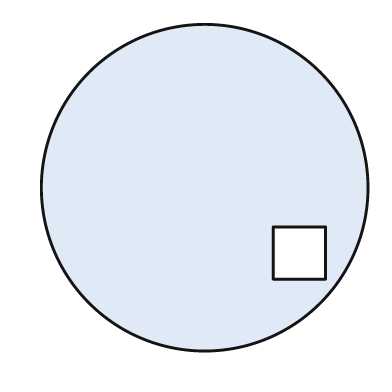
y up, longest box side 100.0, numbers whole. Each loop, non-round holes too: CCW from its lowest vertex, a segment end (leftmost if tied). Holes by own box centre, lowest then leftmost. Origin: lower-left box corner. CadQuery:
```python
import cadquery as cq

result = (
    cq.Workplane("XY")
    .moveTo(50.0, 50.0)
    .circle(50.0)
    .moveTo(71.0, 22.0)
    .lineTo(87.0, 22.0)
    .lineTo(87.0, 38.0)
    .lineTo(71.0, 38.0)
    .close()
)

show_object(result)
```